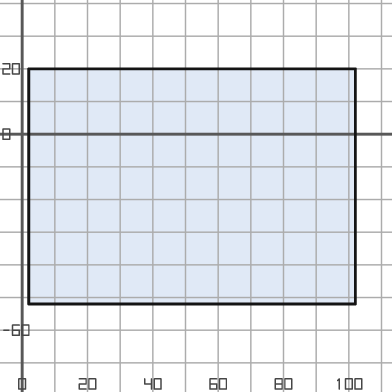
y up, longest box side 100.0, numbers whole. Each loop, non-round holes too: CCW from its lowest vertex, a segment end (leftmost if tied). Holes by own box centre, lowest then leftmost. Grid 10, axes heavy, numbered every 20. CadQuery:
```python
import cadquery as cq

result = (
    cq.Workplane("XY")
    .moveTo(2.0, -52.0)
    .lineTo(102.0, -52.0)
    .lineTo(102.0, 20.0)
    .lineTo(2.0, 20.0)
    .close()
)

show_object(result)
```